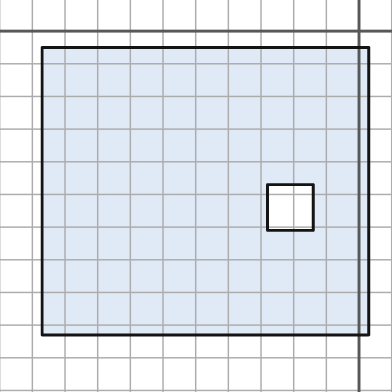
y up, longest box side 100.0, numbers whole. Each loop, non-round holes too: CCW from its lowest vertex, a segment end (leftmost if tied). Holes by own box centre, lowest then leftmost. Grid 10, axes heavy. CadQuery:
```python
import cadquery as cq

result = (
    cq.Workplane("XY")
    .moveTo(-97.0, -93.0)
    .lineTo(3.0, -93.0)
    .lineTo(3.0, -5.0)
    .lineTo(-97.0, -5.0)
    .close()
    .moveTo(-28.0, -61.0)
    .lineTo(-14.0, -61.0)
    .lineTo(-14.0, -47.0)
    .lineTo(-28.0, -47.0)
    .close()
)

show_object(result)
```